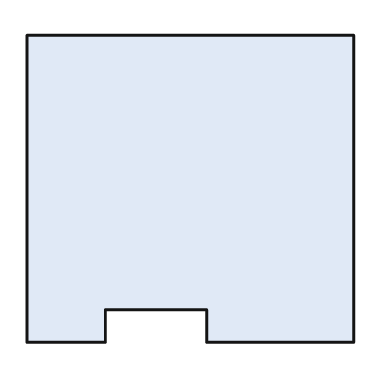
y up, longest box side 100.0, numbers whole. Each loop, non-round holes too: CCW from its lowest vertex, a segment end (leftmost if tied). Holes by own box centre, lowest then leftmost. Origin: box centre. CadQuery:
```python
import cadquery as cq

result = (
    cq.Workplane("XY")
    .moveTo(-50.0, -47.0)
    .lineTo(-26.0, -47.0)
    .lineTo(-26.0, -37.0)
    .lineTo(5.0, -37.0)
    .lineTo(5.0, -47.0)
    .lineTo(50.0, -47.0)
    .lineTo(50.0, 47.0)
    .lineTo(-50.0, 47.0)
    .close()
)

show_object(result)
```